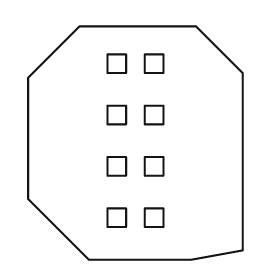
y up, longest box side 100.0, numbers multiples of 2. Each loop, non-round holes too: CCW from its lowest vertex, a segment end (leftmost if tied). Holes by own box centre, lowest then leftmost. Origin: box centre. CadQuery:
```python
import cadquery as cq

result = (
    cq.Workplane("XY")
    .moveTo(-20.0, -50.0)
    .lineTo(24.0, -50.0)
    .lineTo(46.0, -46.0)
    .lineTo(46.0, 30.0)
    .lineTo(26.0, 50.0)
    .lineTo(-24.0, 50.0)
    .lineTo(-46.0, 28.0)
    .lineTo(-46.0, -24.0)
    .close()
    .moveTo(-12.0, -36.0)
    .lineTo(-4.0, -36.0)
    .lineTo(-4.0, -28.0)
    .lineTo(-12.0, -28.0)
    .close()
    .moveTo(4.0, -36.0)
    .lineTo(12.0, -36.0)
    .lineTo(12.0, -28.0)
    .lineTo(4.0, -28.0)
    .close()
    .moveTo(-12.0, -14.0)
    .lineTo(-4.0, -14.0)
    .lineTo(-4.0, -6.0)
    .lineTo(-12.0, -6.0)
    .close()
    .moveTo(4.0, -14.0)
    .lineTo(12.0, -14.0)
    .lineTo(12.0, -6.0)
    .lineTo(4.0, -6.0)
    .close()
    .moveTo(-12.0, 8.0)
    .lineTo(-4.0, 8.0)
    .lineTo(-4.0, 16.0)
    .lineTo(-12.0, 16.0)
    .close()
    .moveTo(4.0, 8.0)
    .lineTo(12.0, 8.0)
    .lineTo(12.0, 16.0)
    .lineTo(4.0, 16.0)
    .close()
    .moveTo(-12.0, 30.0)
    .lineTo(-4.0, 30.0)
    .lineTo(-4.0, 38.0)
    .lineTo(-12.0, 38.0)
    .close()
    .moveTo(4.0, 30.0)
    .lineTo(12.0, 30.0)
    .lineTo(12.0, 38.0)
    .lineTo(4.0, 38.0)
    .close()
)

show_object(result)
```